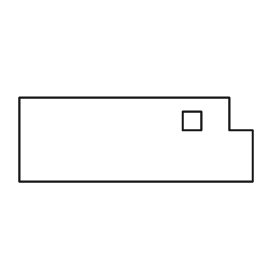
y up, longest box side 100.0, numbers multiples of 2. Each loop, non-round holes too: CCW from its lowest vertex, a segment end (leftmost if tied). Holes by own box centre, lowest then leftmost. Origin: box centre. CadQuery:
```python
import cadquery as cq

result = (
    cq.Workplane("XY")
    .moveTo(-50.0, -18.0)
    .lineTo(50.0, -18.0)
    .lineTo(50.0, 4.0)
    .lineTo(40.0, 4.0)
    .lineTo(40.0, 18.0)
    .lineTo(-50.0, 18.0)
    .close()
    .moveTo(20.0, 4.0)
    .lineTo(28.0, 4.0)
    .lineTo(28.0, 12.0)
    .lineTo(20.0, 12.0)
    .close()
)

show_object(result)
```